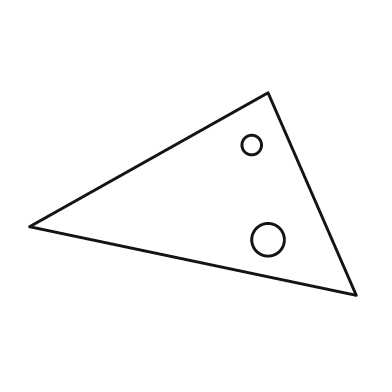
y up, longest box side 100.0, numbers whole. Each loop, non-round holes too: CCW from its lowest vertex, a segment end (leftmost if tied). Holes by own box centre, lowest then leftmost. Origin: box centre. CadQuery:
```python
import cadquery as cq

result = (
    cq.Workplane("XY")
    .moveTo(50.0, -31.0)
    .lineTo(23.0, 31.0)
    .lineTo(-50.0, -10.0)
    .close()
    .moveTo(23.0, -14.0)
    .circle(5.0)
    .moveTo(18.0, 15.0)
    .circle(3.0)
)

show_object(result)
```